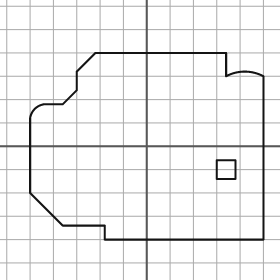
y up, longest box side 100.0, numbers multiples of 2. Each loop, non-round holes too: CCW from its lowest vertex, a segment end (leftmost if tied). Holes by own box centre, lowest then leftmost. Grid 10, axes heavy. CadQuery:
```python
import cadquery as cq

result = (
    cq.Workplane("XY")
    .moveTo(-18.0, -40.0)
    .lineTo(50.0, -40.0)
    .lineTo(50.0, 30.0)
    .threePointArc((42.0, 32.0), (34.0, 30.0))
    .lineTo(34.0, 40.0)
    .lineTo(-22.0, 40.0)
    .lineTo(-30.0, 32.0)
    .lineTo(-30.0, 24.0)
    .lineTo(-36.0, 18.0)
    .lineTo(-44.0, 18.0)
    .threePointArc((-48.0, 16.0), (-50.0, 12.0))
    .lineTo(-50.0, -20.0)
    .lineTo(-36.0, -34.0)
    .lineTo(-18.0, -34.0)
    .close()
    .moveTo(30.0, -14.0)
    .lineTo(38.0, -14.0)
    .lineTo(38.0, -6.0)
    .lineTo(30.0, -6.0)
    .close()
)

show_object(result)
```